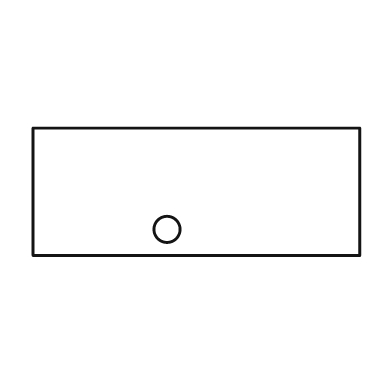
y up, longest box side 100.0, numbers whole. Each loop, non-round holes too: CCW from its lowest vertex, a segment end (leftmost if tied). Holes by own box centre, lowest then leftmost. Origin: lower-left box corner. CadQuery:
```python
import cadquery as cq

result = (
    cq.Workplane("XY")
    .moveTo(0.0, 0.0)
    .lineTo(100.0, 0.0)
    .lineTo(100.0, 39.0)
    .lineTo(0.0, 39.0)
    .close()
    .moveTo(41.0, 8.0)
    .circle(4.0)
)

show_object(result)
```